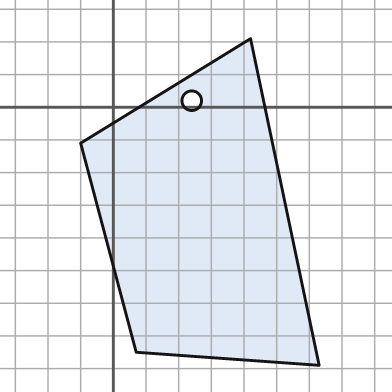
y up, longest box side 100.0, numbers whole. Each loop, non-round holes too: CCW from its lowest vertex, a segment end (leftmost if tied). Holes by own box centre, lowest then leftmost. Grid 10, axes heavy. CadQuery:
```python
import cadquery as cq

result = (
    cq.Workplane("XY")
    .moveTo(63.0, -79.0)
    .lineTo(42.0, 21.0)
    .lineTo(-10.0, -11.0)
    .lineTo(7.0, -75.0)
    .close()
    .moveTo(24.0, 2.0)
    .circle(3.0)
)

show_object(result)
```